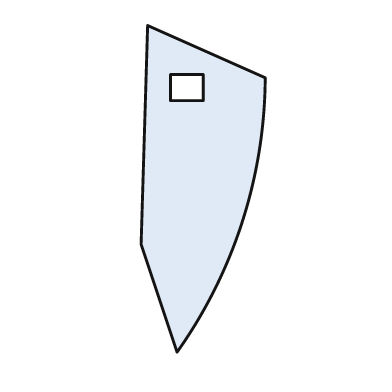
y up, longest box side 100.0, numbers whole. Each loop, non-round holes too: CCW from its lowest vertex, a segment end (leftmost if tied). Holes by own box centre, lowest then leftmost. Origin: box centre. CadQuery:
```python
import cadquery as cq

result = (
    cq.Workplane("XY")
    .moveTo(-8.0, -50.0)
    .threePointArc((12.0, -10.0), (19.0, 34.0))
    .lineTo(-17.0, 50.0)
    .lineTo(-19.0, -17.0)
    .close()
    .moveTo(-10.0, 27.0)
    .lineTo(0.0, 27.0)
    .lineTo(0.0, 35.0)
    .lineTo(-10.0, 35.0)
    .close()
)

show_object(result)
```